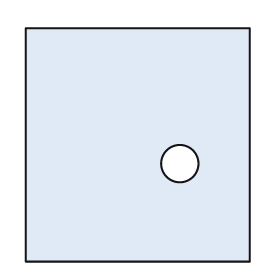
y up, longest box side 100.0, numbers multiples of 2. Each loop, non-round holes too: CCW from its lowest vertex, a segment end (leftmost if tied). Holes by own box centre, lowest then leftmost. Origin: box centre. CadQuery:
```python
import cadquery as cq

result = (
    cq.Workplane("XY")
    .moveTo(-48.0, -50.0)
    .lineTo(48.0, -50.0)
    .lineTo(48.0, 50.0)
    .lineTo(-48.0, 50.0)
    .close()
    .moveTo(18.0, -8.0)
    .circle(8.0)
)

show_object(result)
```